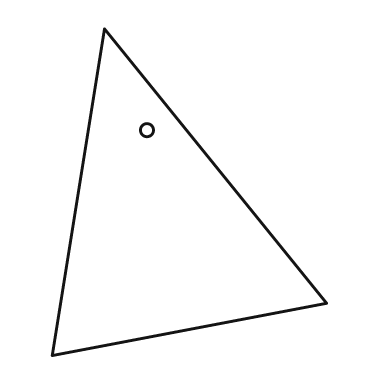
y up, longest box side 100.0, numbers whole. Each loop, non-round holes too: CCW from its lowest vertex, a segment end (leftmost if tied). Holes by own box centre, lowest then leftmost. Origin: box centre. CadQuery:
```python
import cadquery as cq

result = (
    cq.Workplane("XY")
    .moveTo(-42.0, -50.0)
    .lineTo(42.0, -34.0)
    .lineTo(-26.0, 50.0)
    .close()
    .moveTo(-13.0, 19.0)
    .circle(2.0)
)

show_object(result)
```